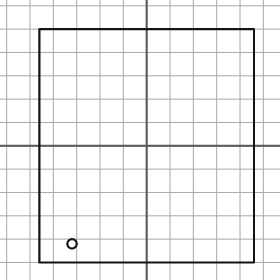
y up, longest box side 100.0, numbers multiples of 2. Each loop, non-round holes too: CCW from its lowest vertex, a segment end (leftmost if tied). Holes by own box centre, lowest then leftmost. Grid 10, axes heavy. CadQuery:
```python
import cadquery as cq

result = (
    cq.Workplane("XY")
    .moveTo(-46.0, -50.0)
    .lineTo(46.0, -50.0)
    .lineTo(46.0, 50.0)
    .lineTo(-46.0, 50.0)
    .close()
    .moveTo(-32.0, -42.0)
    .circle(2.0)
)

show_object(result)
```